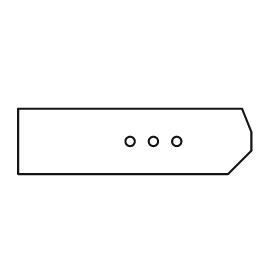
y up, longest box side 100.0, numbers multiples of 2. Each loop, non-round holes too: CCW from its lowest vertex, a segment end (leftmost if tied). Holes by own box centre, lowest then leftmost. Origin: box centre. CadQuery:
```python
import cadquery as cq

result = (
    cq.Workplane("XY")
    .moveTo(-50.0, -14.0)
    .lineTo(40.0, -14.0)
    .lineTo(50.0, -4.0)
    .lineTo(50.0, 4.0)
    .lineTo(46.0, 14.0)
    .lineTo(-50.0, 14.0)
    .close()
    .moveTo(-2.0, 0.0)
    .circle(2.0)
    .moveTo(8.0, 0.0)
    .circle(2.0)
    .moveTo(18.0, 0.0)
    .circle(2.0)
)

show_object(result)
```